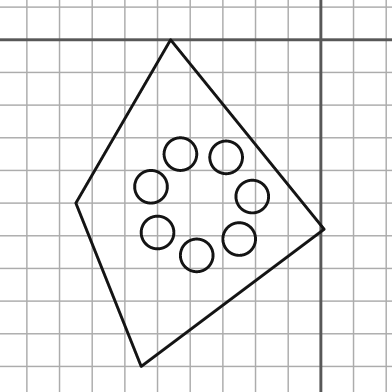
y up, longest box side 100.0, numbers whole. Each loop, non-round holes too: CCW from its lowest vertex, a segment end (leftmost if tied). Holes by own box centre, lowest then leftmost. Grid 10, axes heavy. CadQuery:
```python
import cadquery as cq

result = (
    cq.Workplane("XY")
    .moveTo(-55.0, -100.0)
    .lineTo(1.0, -58.0)
    .lineTo(-46.0, 0.0)
    .lineTo(-75.0, -50.0)
    .close()
    .moveTo(-38.0, -66.0)
    .circle(5.0)
    .moveTo(-25.0, -61.0)
    .circle(5.0)
    .moveTo(-50.0, -59.0)
    .circle(5.0)
    .moveTo(-21.0, -48.0)
    .circle(5.0)
    .moveTo(-52.0, -45.0)
    .circle(5.0)
    .moveTo(-29.0, -36.0)
    .circle(5.0)
    .moveTo(-43.0, -35.0)
    .circle(5.0)
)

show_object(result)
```